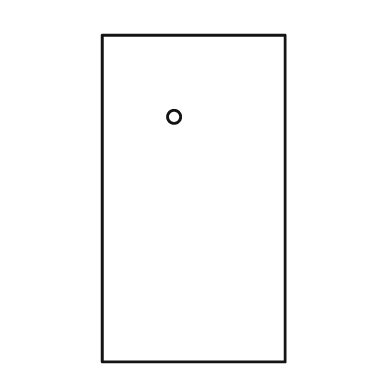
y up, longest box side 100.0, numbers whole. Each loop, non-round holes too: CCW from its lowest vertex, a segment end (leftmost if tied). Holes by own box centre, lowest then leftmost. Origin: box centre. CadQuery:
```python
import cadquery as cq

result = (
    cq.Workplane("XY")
    .moveTo(-28.0, -50.0)
    .lineTo(28.0, -50.0)
    .lineTo(28.0, 50.0)
    .lineTo(-28.0, 50.0)
    .close()
    .moveTo(-6.0, 25.0)
    .circle(2.0)
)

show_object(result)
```